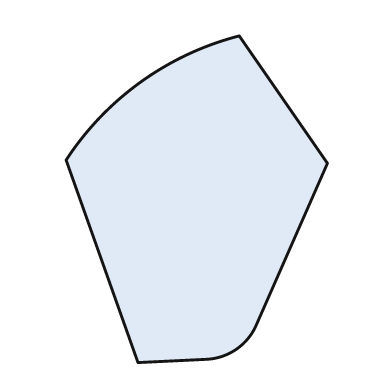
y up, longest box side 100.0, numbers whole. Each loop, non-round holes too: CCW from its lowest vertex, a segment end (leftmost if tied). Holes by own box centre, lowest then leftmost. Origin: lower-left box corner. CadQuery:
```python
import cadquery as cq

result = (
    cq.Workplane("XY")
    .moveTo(22.0, 0.0)
    .lineTo(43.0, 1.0)
    .threePointArc((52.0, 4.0), (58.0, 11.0))
    .lineTo(80.0, 61.0)
    .lineTo(53.0, 100.0)
    .threePointArc((23.0, 86.0), (0.0, 62.0))
    .close()
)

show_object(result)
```